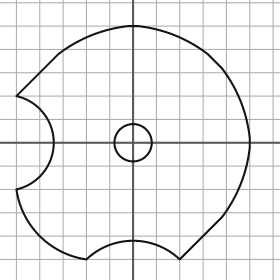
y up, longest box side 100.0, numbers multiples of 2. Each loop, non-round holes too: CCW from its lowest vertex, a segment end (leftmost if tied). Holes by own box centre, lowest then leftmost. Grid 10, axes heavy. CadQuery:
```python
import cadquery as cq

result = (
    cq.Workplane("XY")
    .moveTo(-20.0, -50.0)
    .threePointArc((0.0, -42.0), (20.0, -50.0))
    .lineTo(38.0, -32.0)
    .threePointArc((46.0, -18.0), (50.0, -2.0))
    .lineTo(50.0, 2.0)
    .threePointArc((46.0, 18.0), (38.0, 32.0))
    .lineTo(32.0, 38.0)
    .threePointArc((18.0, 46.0), (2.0, 50.0))
    .lineTo(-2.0, 50.0)
    .threePointArc((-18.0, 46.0), (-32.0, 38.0))
    .lineTo(-50.0, 20.0)
    .threePointArc((-34.0, 0.0), (-50.0, -20.0))
    .threePointArc((-40.0, -40.0), (-20.0, -50.0))
    .close()
    .moveTo(0.0, 0.0)
    .circle(8.0)
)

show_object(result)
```